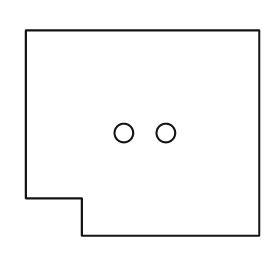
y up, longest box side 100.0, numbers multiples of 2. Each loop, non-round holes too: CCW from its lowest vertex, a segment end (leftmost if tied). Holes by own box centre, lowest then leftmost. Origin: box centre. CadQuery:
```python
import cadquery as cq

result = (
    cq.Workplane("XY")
    .moveTo(-26.0, -44.0)
    .lineTo(50.0, -44.0)
    .lineTo(50.0, 44.0)
    .lineTo(-50.0, 44.0)
    .lineTo(-50.0, -28.0)
    .lineTo(-26.0, -28.0)
    .close()
    .moveTo(-8.0, 0.0)
    .circle(4.0)
    .moveTo(10.0, 0.0)
    .circle(4.0)
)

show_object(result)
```